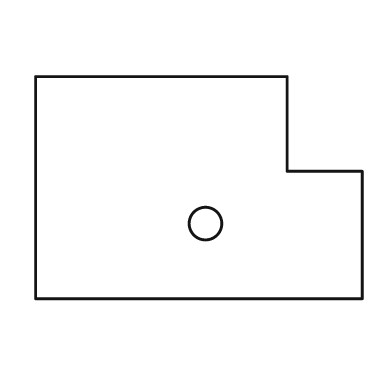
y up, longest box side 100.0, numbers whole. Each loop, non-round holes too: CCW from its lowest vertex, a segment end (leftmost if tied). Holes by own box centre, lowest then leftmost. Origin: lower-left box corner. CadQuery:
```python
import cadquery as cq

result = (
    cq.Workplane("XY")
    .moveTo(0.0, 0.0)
    .lineTo(100.0, 0.0)
    .lineTo(100.0, 39.0)
    .lineTo(77.0, 39.0)
    .lineTo(77.0, 68.0)
    .lineTo(0.0, 68.0)
    .close()
    .moveTo(52.0, 23.0)
    .circle(5.0)
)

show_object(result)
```